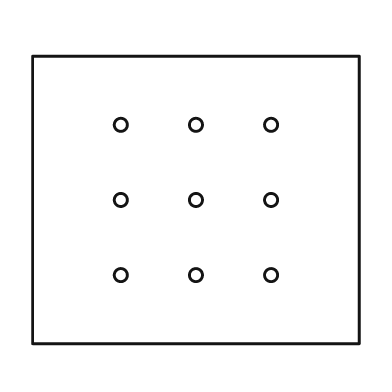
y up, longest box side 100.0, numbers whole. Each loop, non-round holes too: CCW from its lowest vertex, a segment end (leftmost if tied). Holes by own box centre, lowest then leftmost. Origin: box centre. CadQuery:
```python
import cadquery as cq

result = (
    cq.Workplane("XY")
    .moveTo(-50.0, -44.0)
    .lineTo(50.0, -44.0)
    .lineTo(50.0, 44.0)
    .lineTo(-50.0, 44.0)
    .close()
    .moveTo(-23.0, -23.0)
    .circle(2.0)
    .moveTo(0.0, -23.0)
    .circle(2.0)
    .moveTo(23.0, -23.0)
    .circle(2.0)
    .moveTo(-23.0, 0.0)
    .circle(2.0)
    .moveTo(0.0, 0.0)
    .circle(2.0)
    .moveTo(23.0, 0.0)
    .circle(2.0)
    .moveTo(-23.0, 23.0)
    .circle(2.0)
    .moveTo(0.0, 23.0)
    .circle(2.0)
    .moveTo(23.0, 23.0)
    .circle(2.0)
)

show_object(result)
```